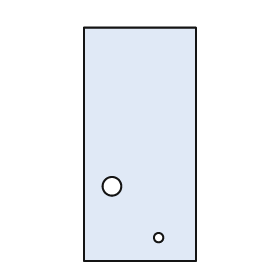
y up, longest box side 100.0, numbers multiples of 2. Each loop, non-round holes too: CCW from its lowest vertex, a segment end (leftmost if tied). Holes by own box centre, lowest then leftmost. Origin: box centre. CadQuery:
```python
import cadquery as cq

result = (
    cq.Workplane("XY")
    .moveTo(-24.0, -50.0)
    .lineTo(24.0, -50.0)
    .lineTo(24.0, 50.0)
    .lineTo(-24.0, 50.0)
    .close()
    .moveTo(8.0, -40.0)
    .circle(2.0)
    .moveTo(-12.0, -18.0)
    .circle(4.0)
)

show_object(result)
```